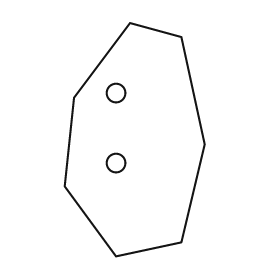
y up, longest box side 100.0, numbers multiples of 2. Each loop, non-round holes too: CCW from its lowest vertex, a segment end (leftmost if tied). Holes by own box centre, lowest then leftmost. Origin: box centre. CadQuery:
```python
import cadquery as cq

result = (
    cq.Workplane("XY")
    .moveTo(-8.0, -50.0)
    .lineTo(20.0, -44.0)
    .lineTo(30.0, -2.0)
    .lineTo(20.0, 44.0)
    .lineTo(-2.0, 50.0)
    .lineTo(-26.0, 18.0)
    .lineTo(-30.0, -20.0)
    .close()
    .moveTo(-8.0, -10.0)
    .circle(4.0)
    .moveTo(-8.0, 20.0)
    .circle(4.0)
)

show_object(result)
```